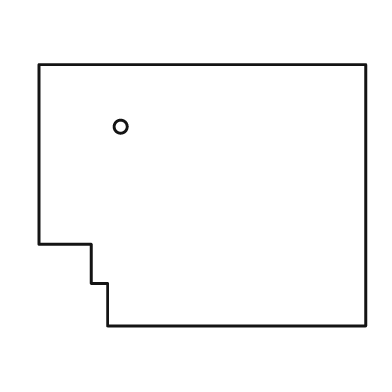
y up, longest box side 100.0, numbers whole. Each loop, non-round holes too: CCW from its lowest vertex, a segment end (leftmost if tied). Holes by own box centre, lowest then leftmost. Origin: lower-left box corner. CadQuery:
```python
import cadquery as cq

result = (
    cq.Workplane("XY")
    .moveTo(21.0, 0.0)
    .lineTo(100.0, 0.0)
    .lineTo(100.0, 80.0)
    .lineTo(0.0, 80.0)
    .lineTo(0.0, 25.0)
    .lineTo(16.0, 25.0)
    .lineTo(16.0, 13.0)
    .lineTo(21.0, 13.0)
    .close()
    .moveTo(25.0, 61.0)
    .circle(2.0)
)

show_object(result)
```